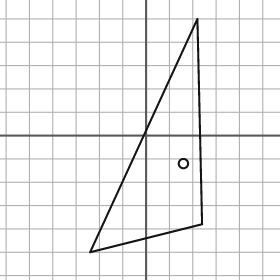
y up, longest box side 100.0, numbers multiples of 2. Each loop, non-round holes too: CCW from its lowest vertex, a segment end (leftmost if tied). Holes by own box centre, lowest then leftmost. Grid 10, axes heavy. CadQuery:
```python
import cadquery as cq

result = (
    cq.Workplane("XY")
    .moveTo(-24.0, -50.0)
    .lineTo(24.0, -38.0)
    .lineTo(22.0, 50.0)
    .close()
    .moveTo(16.0, -12.0)
    .circle(2.0)
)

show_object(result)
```